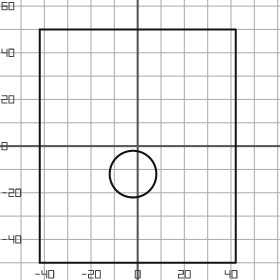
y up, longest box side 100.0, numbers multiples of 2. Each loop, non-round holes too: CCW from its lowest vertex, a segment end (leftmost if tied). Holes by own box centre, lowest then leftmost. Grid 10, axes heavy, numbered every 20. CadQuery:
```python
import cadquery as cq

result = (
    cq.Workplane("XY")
    .moveTo(-42.0, -50.0)
    .lineTo(42.0, -50.0)
    .lineTo(42.0, 50.0)
    .lineTo(-42.0, 50.0)
    .close()
    .moveTo(-2.0, -12.0)
    .circle(10.0)
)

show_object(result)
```